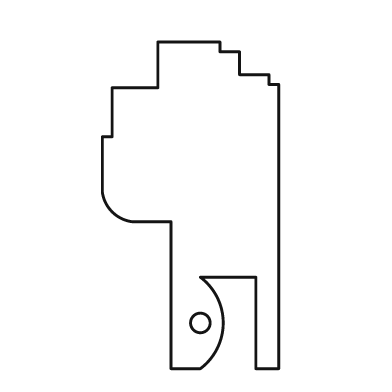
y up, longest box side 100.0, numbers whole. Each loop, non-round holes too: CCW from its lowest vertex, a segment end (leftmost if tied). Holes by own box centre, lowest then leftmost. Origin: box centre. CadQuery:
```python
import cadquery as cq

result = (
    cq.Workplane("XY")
    .moveTo(-6.0, -50.0)
    .lineTo(3.0, -50.0)
    .threePointArc((10.0, -36.0), (3.0, -22.0))
    .lineTo(20.0, -22.0)
    .lineTo(20.0, -50.0)
    .lineTo(27.0, -50.0)
    .lineTo(27.0, 37.0)
    .lineTo(24.0, 37.0)
    .lineTo(24.0, 40.0)
    .lineTo(15.0, 40.0)
    .lineTo(15.0, 47.0)
    .lineTo(9.0, 47.0)
    .lineTo(9.0, 50.0)
    .lineTo(-10.0, 50.0)
    .lineTo(-10.0, 36.0)
    .lineTo(-24.0, 36.0)
    .lineTo(-24.0, 21.0)
    .lineTo(-27.0, 21.0)
    .lineTo(-27.0, 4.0)
    .threePointArc((-24.0, -2.0), (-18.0, -5.0))
    .lineTo(-6.0, -5.0)
    .close()
    .moveTo(3.0, -36.0)
    .circle(3.0)
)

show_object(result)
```